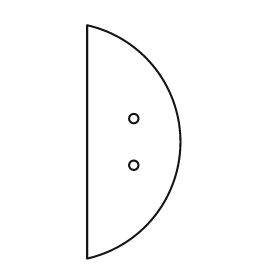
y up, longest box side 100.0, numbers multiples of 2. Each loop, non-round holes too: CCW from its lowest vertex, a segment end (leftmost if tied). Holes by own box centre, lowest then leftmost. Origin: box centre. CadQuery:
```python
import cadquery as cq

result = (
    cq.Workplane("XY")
    .moveTo(-20.0, -50.0)
    .threePointArc((20.0, 0.0), (-20.0, 50.0))
    .close()
    .moveTo(0.0, -10.0)
    .circle(2.0)
    .moveTo(0.0, 10.0)
    .circle(2.0)
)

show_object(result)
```